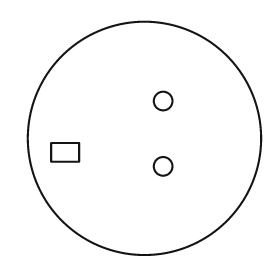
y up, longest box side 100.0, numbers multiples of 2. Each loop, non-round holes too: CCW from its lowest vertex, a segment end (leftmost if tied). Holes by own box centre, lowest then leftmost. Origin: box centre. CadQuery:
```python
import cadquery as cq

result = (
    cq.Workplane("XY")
    .moveTo(0.0, 0.0)
    .circle(50.0)
    .moveTo(8.0, -12.0)
    .circle(4.0)
    .moveTo(-40.0, -10.0)
    .lineTo(-28.0, -10.0)
    .lineTo(-28.0, -2.0)
    .lineTo(-40.0, -2.0)
    .close()
    .moveTo(8.0, 16.0)
    .circle(4.0)
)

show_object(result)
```